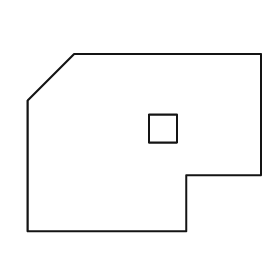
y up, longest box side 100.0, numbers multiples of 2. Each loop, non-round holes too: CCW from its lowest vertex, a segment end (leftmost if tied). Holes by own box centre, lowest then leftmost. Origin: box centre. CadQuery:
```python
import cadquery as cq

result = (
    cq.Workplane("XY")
    .moveTo(-50.0, -38.0)
    .lineTo(18.0, -38.0)
    .lineTo(18.0, -14.0)
    .lineTo(50.0, -14.0)
    .lineTo(50.0, 38.0)
    .lineTo(-30.0, 38.0)
    .lineTo(-50.0, 18.0)
    .close()
    .moveTo(2.0, 0.0)
    .lineTo(14.0, 0.0)
    .lineTo(14.0, 12.0)
    .lineTo(2.0, 12.0)
    .close()
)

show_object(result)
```